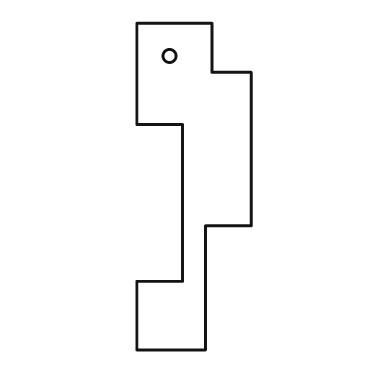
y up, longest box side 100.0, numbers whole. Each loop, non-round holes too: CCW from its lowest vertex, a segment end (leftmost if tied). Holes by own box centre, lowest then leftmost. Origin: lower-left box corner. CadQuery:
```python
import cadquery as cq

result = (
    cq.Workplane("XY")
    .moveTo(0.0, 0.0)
    .lineTo(21.0, 0.0)
    .lineTo(21.0, 38.0)
    .lineTo(35.0, 38.0)
    .lineTo(35.0, 85.0)
    .lineTo(23.0, 85.0)
    .lineTo(23.0, 100.0)
    .lineTo(0.0, 100.0)
    .lineTo(0.0, 69.0)
    .lineTo(14.0, 69.0)
    .lineTo(14.0, 21.0)
    .lineTo(0.0, 21.0)
    .close()
    .moveTo(10.0, 90.0)
    .circle(2.0)
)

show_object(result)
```